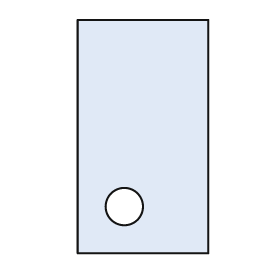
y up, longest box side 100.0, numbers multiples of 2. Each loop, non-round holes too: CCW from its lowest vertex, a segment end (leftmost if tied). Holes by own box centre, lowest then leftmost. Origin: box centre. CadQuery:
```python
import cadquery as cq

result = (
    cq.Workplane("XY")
    .moveTo(-28.0, -50.0)
    .lineTo(28.0, -50.0)
    .lineTo(28.0, 50.0)
    .lineTo(-28.0, 50.0)
    .close()
    .moveTo(-8.0, -30.0)
    .circle(8.0)
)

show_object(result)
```